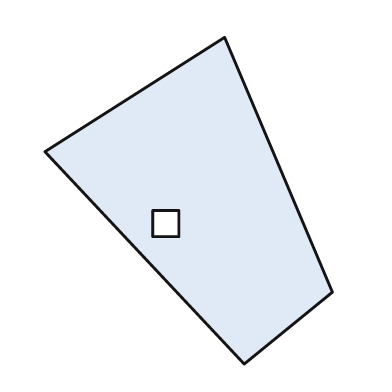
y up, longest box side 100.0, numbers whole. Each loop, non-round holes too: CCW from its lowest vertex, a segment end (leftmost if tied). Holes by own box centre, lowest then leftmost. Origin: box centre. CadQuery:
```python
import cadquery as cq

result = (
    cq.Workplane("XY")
    .moveTo(17.0, -50.0)
    .lineTo(44.0, -28.0)
    .lineTo(11.0, 50.0)
    .lineTo(-44.0, 15.0)
    .close()
    .moveTo(-11.0, -11.0)
    .lineTo(-3.0, -11.0)
    .lineTo(-3.0, -3.0)
    .lineTo(-11.0, -3.0)
    .close()
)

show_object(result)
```